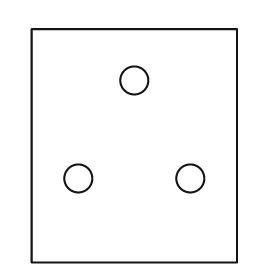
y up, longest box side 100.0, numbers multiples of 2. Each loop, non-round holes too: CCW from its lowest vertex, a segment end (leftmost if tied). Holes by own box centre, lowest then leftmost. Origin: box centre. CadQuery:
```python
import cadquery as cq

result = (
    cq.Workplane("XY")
    .moveTo(-44.0, -50.0)
    .lineTo(44.0, -50.0)
    .lineTo(44.0, 50.0)
    .lineTo(-44.0, 50.0)
    .close()
    .moveTo(-24.0, -14.0)
    .circle(6.0)
    .moveTo(24.0, -14.0)
    .circle(6.0)
    .moveTo(0.0, 28.0)
    .circle(6.0)
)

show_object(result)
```